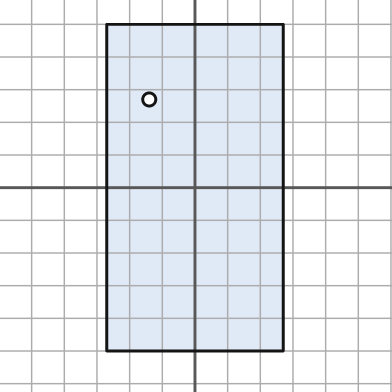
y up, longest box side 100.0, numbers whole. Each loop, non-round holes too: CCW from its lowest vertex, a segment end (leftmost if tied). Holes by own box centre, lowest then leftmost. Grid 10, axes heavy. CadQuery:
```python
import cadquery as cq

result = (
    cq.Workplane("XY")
    .moveTo(-27.0, -50.0)
    .lineTo(27.0, -50.0)
    .lineTo(27.0, 50.0)
    .lineTo(-27.0, 50.0)
    .close()
    .moveTo(-14.0, 27.0)
    .circle(2.0)
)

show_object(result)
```